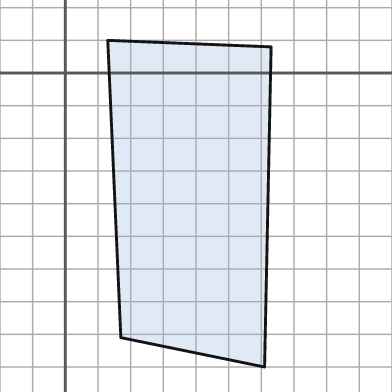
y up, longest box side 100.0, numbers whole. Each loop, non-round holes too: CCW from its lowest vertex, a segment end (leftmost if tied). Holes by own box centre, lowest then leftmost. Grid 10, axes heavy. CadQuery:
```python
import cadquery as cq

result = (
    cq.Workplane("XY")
    .moveTo(61.0, -90.0)
    .lineTo(63.0, 8.0)
    .lineTo(13.0, 10.0)
    .lineTo(17.0, -81.0)
    .close()
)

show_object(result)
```